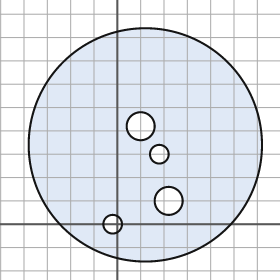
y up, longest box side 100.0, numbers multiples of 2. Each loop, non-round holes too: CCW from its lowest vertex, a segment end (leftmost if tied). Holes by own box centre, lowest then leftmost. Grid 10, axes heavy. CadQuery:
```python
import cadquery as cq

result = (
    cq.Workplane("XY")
    .moveTo(12.0, 34.0)
    .circle(50.0)
    .moveTo(-2.0, 0.0)
    .circle(4.0)
    .moveTo(22.0, 10.0)
    .circle(6.0)
    .moveTo(18.0, 30.0)
    .circle(4.0)
    .moveTo(10.0, 42.0)
    .circle(6.0)
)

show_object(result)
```